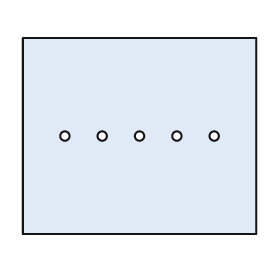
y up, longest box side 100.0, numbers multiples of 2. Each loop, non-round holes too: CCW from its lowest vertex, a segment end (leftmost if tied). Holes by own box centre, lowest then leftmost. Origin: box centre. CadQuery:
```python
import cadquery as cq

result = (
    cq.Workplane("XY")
    .moveTo(-50.0, -42.0)
    .lineTo(50.0, -42.0)
    .lineTo(50.0, 42.0)
    .lineTo(-50.0, 42.0)
    .close()
    .moveTo(-32.0, 0.0)
    .circle(2.0)
    .moveTo(-16.0, 0.0)
    .circle(2.0)
    .moveTo(0.0, 0.0)
    .circle(2.0)
    .moveTo(16.0, 0.0)
    .circle(2.0)
    .moveTo(32.0, 0.0)
    .circle(2.0)
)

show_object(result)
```